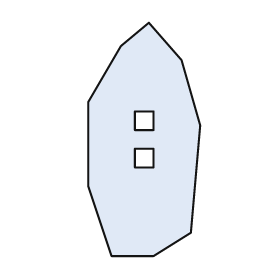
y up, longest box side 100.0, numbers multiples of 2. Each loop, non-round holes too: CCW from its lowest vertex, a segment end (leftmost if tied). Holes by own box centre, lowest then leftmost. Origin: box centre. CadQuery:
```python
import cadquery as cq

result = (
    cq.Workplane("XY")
    .moveTo(-14.0, -50.0)
    .lineTo(4.0, -50.0)
    .lineTo(20.0, -40.0)
    .lineTo(24.0, 6.0)
    .lineTo(16.0, 34.0)
    .lineTo(2.0, 50.0)
    .lineTo(-10.0, 40.0)
    .lineTo(-24.0, 16.0)
    .lineTo(-24.0, -20.0)
    .close()
    .moveTo(-4.0, -12.0)
    .lineTo(4.0, -12.0)
    .lineTo(4.0, -4.0)
    .lineTo(-4.0, -4.0)
    .close()
    .moveTo(-4.0, 4.0)
    .lineTo(4.0, 4.0)
    .lineTo(4.0, 12.0)
    .lineTo(-4.0, 12.0)
    .close()
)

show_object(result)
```